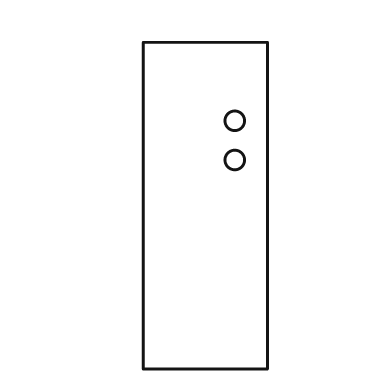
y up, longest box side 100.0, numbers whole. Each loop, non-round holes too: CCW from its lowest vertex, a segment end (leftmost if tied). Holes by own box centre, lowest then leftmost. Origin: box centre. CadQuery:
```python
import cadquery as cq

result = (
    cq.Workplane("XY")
    .moveTo(-19.0, -50.0)
    .lineTo(19.0, -50.0)
    .lineTo(19.0, 50.0)
    .lineTo(-19.0, 50.0)
    .close()
    .moveTo(9.0, 14.0)
    .circle(3.0)
    .moveTo(9.0, 26.0)
    .circle(3.0)
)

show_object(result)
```